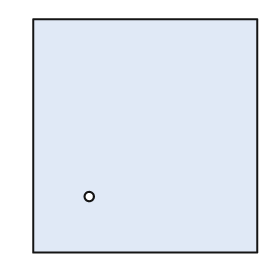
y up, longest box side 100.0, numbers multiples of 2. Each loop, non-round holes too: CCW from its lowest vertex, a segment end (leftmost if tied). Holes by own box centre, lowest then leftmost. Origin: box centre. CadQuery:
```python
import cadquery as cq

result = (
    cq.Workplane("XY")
    .moveTo(-48.0, -50.0)
    .lineTo(48.0, -50.0)
    .lineTo(48.0, 50.0)
    .lineTo(-48.0, 50.0)
    .close()
    .moveTo(-24.0, -26.0)
    .circle(2.0)
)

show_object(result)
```